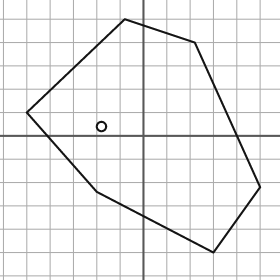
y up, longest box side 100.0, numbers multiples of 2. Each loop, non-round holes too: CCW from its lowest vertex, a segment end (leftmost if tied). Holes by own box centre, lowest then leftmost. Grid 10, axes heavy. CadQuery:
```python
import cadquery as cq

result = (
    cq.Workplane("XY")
    .moveTo(30.0, -50.0)
    .lineTo(50.0, -22.0)
    .lineTo(22.0, 40.0)
    .lineTo(-8.0, 50.0)
    .lineTo(-50.0, 10.0)
    .lineTo(-20.0, -24.0)
    .close()
    .moveTo(-18.0, 4.0)
    .circle(2.0)
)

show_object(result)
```